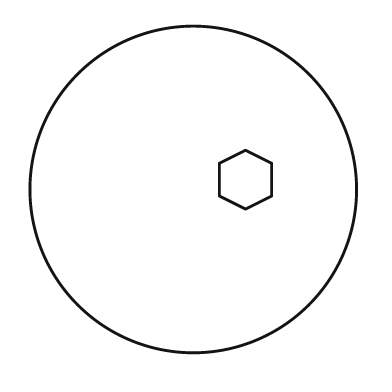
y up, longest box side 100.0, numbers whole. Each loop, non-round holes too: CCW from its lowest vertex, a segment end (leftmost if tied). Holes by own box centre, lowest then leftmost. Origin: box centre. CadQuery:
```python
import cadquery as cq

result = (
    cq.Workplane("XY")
    .moveTo(0.0, 0.0)
    .circle(50.0)
    .moveTo(16.0, -6.0)
    .lineTo(24.0, -2.0)
    .lineTo(24.0, 8.0)
    .lineTo(16.0, 12.0)
    .lineTo(8.0, 8.0)
    .lineTo(8.0, -2.0)
    .close()
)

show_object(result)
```